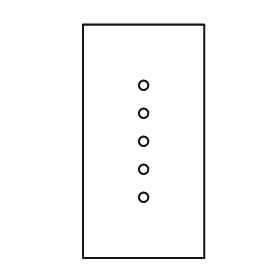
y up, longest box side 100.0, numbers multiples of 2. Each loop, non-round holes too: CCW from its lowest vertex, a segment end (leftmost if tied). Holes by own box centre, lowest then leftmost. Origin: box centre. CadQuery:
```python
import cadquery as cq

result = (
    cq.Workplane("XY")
    .moveTo(-26.0, -50.0)
    .lineTo(26.0, -50.0)
    .lineTo(26.0, 50.0)
    .lineTo(-26.0, 50.0)
    .close()
    .moveTo(0.0, -24.0)
    .circle(2.0)
    .moveTo(0.0, -12.0)
    .circle(2.0)
    .moveTo(0.0, 0.0)
    .circle(2.0)
    .moveTo(0.0, 12.0)
    .circle(2.0)
    .moveTo(0.0, 24.0)
    .circle(2.0)
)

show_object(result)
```